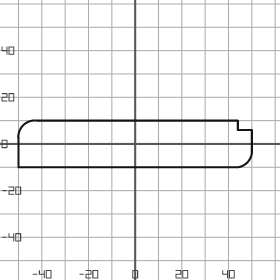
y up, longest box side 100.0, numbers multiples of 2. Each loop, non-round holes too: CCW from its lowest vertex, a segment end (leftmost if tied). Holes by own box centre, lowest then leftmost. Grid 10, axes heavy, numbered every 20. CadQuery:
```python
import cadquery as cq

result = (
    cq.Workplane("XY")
    .moveTo(-50.0, -10.0)
    .lineTo(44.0, -10.0)
    .threePointArc((48.0, -8.0), (50.0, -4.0))
    .lineTo(50.0, 6.0)
    .lineTo(44.0, 6.0)
    .lineTo(44.0, 10.0)
    .lineTo(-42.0, 10.0)
    .threePointArc((-48.0, 8.0), (-50.0, 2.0))
    .close()
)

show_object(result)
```